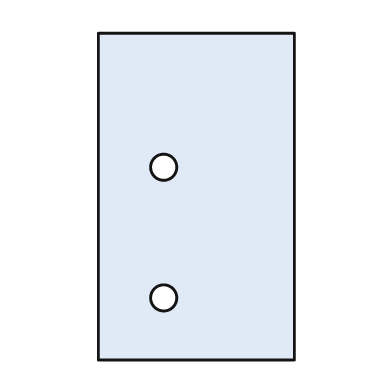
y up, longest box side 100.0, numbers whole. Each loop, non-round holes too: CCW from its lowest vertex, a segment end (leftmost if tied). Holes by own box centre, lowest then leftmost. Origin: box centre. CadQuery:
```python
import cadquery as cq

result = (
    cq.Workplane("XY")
    .moveTo(-30.0, -50.0)
    .lineTo(30.0, -50.0)
    .lineTo(30.0, 50.0)
    .lineTo(-30.0, 50.0)
    .close()
    .moveTo(-10.0, -31.0)
    .circle(4.0)
    .moveTo(-10.0, 9.0)
    .circle(4.0)
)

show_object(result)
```